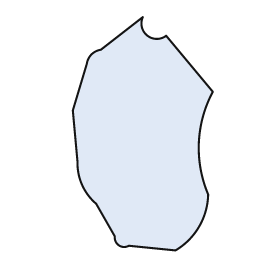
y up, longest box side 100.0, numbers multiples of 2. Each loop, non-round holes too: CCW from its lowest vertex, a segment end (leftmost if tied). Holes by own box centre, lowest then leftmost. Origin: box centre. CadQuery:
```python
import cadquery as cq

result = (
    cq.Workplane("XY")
    .moveTo(14.0, -50.0)
    .threePointArc((24.0, -40.0), (28.0, -26.0))
    .threePointArc((24.0, -4.0), (30.0, 18.0))
    .lineTo(10.0, 42.0)
    .threePointArc((2.0, 42.0), (0.0, 50.0))
    .lineTo(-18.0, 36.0)
    .threePointArc((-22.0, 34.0), (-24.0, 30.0))
    .lineTo(-30.0, 10.0)
    .lineTo(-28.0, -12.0)
    .threePointArc((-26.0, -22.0), (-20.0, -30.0))
    .lineTo(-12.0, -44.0)
    .threePointArc((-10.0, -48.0), (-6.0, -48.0))
    .close()
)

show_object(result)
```